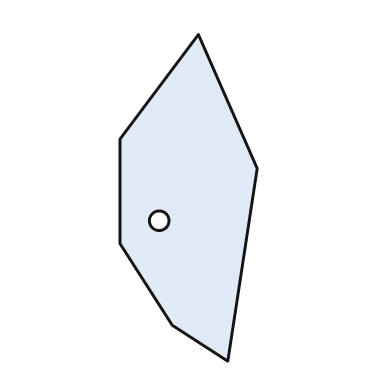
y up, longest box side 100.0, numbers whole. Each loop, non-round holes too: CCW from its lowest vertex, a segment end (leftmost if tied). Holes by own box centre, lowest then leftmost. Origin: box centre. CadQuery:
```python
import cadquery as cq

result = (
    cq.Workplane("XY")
    .moveTo(12.0, -50.0)
    .lineTo(21.0, 9.0)
    .lineTo(3.0, 50.0)
    .lineTo(-21.0, 18.0)
    .lineTo(-21.0, -14.0)
    .lineTo(-5.0, -39.0)
    .close()
    .moveTo(-9.0, -7.0)
    .circle(3.0)
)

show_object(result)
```